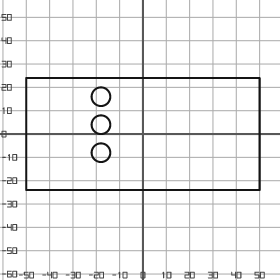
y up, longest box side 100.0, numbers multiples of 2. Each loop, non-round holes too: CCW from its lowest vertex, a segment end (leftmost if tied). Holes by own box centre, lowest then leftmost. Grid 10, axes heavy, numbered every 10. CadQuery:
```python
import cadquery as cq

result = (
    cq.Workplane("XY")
    .moveTo(-50.0, -24.0)
    .lineTo(50.0, -24.0)
    .lineTo(50.0, 24.0)
    .lineTo(-50.0, 24.0)
    .close()
    .moveTo(-18.0, -8.0)
    .circle(4.0)
    .moveTo(-18.0, 4.0)
    .circle(4.0)
    .moveTo(-18.0, 16.0)
    .circle(4.0)
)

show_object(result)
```